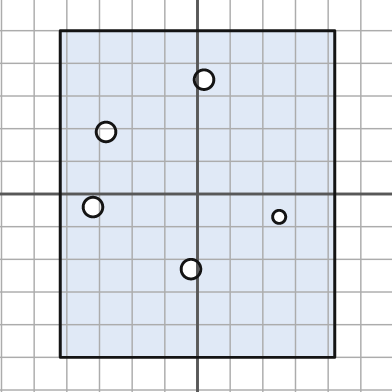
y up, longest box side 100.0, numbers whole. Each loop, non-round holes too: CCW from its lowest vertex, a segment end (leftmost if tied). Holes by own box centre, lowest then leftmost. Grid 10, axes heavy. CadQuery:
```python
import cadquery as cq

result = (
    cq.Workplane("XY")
    .moveTo(-42.0, -50.0)
    .lineTo(42.0, -50.0)
    .lineTo(42.0, 50.0)
    .lineTo(-42.0, 50.0)
    .close()
    .moveTo(-2.0, -23.0)
    .circle(3.0)
    .moveTo(25.0, -7.0)
    .circle(2.0)
    .moveTo(-32.0, -4.0)
    .circle(3.0)
    .moveTo(-28.0, 19.0)
    .circle(3.0)
    .moveTo(2.0, 35.0)
    .circle(3.0)
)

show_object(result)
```